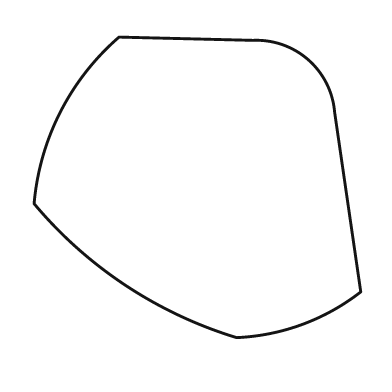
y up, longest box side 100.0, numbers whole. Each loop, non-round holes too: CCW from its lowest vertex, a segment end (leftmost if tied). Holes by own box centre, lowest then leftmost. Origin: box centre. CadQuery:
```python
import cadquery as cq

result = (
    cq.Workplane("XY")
    .moveTo(12.0, -46.0)
    .threePointArc((32.0, -42.0), (50.0, -32.0))
    .lineTo(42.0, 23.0)
    .threePointArc((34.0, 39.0), (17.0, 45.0))
    .lineTo(-24.0, 46.0)
    .threePointArc((-42.0, 23.0), (-50.0, -5.0))
    .threePointArc((-22.0, -30.0), (12.0, -46.0))
    .close()
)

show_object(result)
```